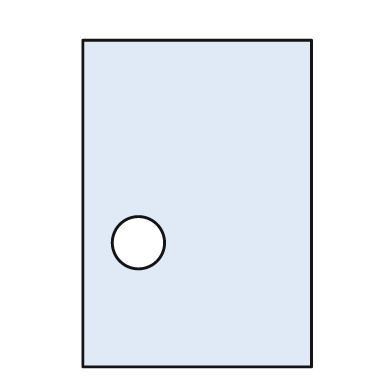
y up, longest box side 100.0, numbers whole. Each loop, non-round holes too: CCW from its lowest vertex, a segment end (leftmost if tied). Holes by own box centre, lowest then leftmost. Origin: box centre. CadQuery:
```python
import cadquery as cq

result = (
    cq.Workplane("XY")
    .moveTo(-35.0, -50.0)
    .lineTo(35.0, -50.0)
    .lineTo(35.0, 50.0)
    .lineTo(-35.0, 50.0)
    .close()
    .moveTo(-18.0, -12.0)
    .circle(8.0)
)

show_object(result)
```